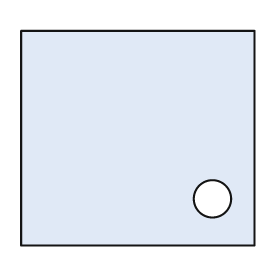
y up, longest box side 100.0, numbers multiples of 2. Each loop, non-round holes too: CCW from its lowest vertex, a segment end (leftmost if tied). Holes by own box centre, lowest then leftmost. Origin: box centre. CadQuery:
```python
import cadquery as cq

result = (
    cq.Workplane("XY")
    .moveTo(-50.0, -46.0)
    .lineTo(50.0, -46.0)
    .lineTo(50.0, 46.0)
    .lineTo(-50.0, 46.0)
    .close()
    .moveTo(32.0, -26.0)
    .circle(8.0)
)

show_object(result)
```